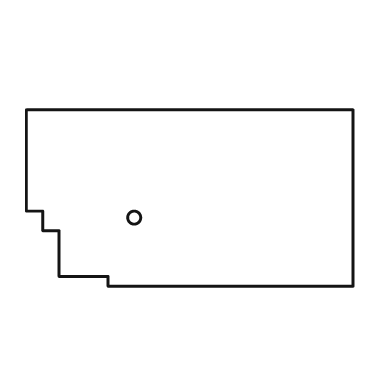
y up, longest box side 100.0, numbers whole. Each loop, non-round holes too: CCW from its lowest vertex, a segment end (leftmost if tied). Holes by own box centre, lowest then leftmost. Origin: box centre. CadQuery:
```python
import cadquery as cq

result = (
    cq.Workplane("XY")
    .moveTo(-25.0, -27.0)
    .lineTo(50.0, -27.0)
    .lineTo(50.0, 27.0)
    .lineTo(-50.0, 27.0)
    .lineTo(-50.0, -4.0)
    .lineTo(-45.0, -4.0)
    .lineTo(-45.0, -10.0)
    .lineTo(-40.0, -10.0)
    .lineTo(-40.0, -24.0)
    .lineTo(-25.0, -24.0)
    .close()
    .moveTo(-17.0, -6.0)
    .circle(2.0)
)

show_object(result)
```